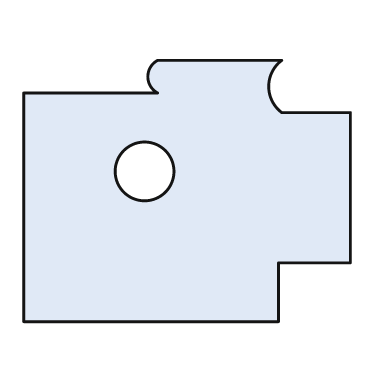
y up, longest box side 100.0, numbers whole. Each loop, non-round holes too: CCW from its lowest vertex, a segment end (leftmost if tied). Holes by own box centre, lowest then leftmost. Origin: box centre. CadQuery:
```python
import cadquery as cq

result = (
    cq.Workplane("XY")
    .moveTo(-50.0, -40.0)
    .lineTo(28.0, -40.0)
    .lineTo(28.0, -22.0)
    .lineTo(50.0, -22.0)
    .lineTo(50.0, 24.0)
    .lineTo(29.0, 24.0)
    .threePointArc((25.0, 32.0), (29.0, 40.0))
    .lineTo(-9.0, 40.0)
    .threePointArc((-12.0, 35.0), (-9.0, 30.0))
    .lineTo(-50.0, 30.0)
    .close()
    .moveTo(-13.0, 6.0)
    .circle(9.0)
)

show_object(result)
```